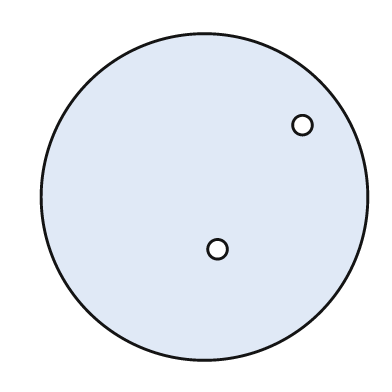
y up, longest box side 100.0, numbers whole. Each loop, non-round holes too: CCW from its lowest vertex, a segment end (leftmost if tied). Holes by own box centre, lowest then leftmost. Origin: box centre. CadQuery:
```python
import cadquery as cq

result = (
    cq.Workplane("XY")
    .moveTo(0.0, 0.0)
    .circle(50.0)
    .moveTo(4.0, -16.0)
    .circle(3.0)
    .moveTo(30.0, 22.0)
    .circle(3.0)
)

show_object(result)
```